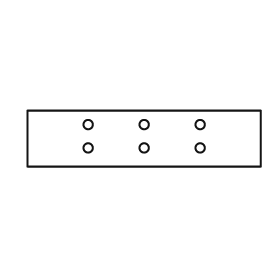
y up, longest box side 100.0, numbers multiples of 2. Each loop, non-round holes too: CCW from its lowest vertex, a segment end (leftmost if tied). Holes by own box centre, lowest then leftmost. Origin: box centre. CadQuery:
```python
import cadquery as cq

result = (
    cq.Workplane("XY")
    .moveTo(-50.0, -12.0)
    .lineTo(50.0, -12.0)
    .lineTo(50.0, 12.0)
    .lineTo(-50.0, 12.0)
    .close()
    .moveTo(-24.0, -4.0)
    .circle(2.0)
    .moveTo(0.0, -4.0)
    .circle(2.0)
    .moveTo(24.0, -4.0)
    .circle(2.0)
    .moveTo(-24.0, 6.0)
    .circle(2.0)
    .moveTo(0.0, 6.0)
    .circle(2.0)
    .moveTo(24.0, 6.0)
    .circle(2.0)
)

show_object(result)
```